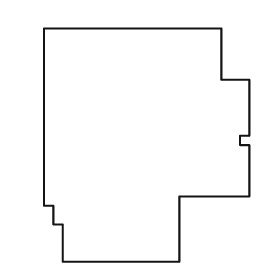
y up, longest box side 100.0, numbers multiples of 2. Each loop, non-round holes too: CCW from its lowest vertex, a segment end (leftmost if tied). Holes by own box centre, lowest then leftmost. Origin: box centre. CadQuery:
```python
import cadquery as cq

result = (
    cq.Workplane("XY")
    .moveTo(-36.0, -50.0)
    .lineTo(14.0, -50.0)
    .lineTo(14.0, -22.0)
    .lineTo(44.0, -22.0)
    .lineTo(44.0, 0.0)
    .lineTo(40.0, 0.0)
    .lineTo(40.0, 4.0)
    .lineTo(44.0, 4.0)
    .lineTo(44.0, 28.0)
    .lineTo(32.0, 28.0)
    .lineTo(32.0, 50.0)
    .lineTo(-44.0, 50.0)
    .lineTo(-44.0, -26.0)
    .lineTo(-40.0, -26.0)
    .lineTo(-40.0, -34.0)
    .lineTo(-36.0, -34.0)
    .close()
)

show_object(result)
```